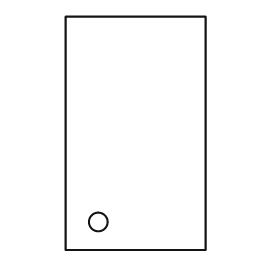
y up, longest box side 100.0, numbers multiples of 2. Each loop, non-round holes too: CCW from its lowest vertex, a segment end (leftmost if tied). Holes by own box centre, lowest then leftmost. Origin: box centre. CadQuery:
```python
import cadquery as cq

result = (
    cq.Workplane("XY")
    .moveTo(-30.0, -50.0)
    .lineTo(30.0, -50.0)
    .lineTo(30.0, 50.0)
    .lineTo(-30.0, 50.0)
    .close()
    .moveTo(-16.0, -38.0)
    .circle(4.0)
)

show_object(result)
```